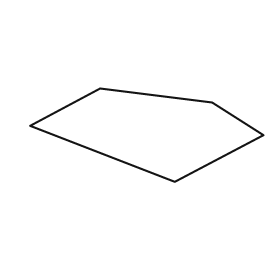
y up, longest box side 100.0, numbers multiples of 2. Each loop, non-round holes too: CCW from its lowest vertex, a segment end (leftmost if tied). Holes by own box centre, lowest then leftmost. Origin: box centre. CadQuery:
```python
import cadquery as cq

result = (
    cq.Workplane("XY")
    .moveTo(12.0, -20.0)
    .lineTo(50.0, 0.0)
    .lineTo(28.0, 14.0)
    .lineTo(-20.0, 20.0)
    .lineTo(-50.0, 4.0)
    .close()
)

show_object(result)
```